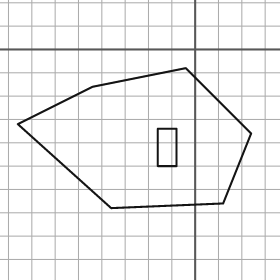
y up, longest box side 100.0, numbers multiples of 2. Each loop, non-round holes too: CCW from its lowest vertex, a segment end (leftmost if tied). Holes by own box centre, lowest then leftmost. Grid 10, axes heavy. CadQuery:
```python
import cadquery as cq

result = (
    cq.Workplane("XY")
    .moveTo(-36.0, -68.0)
    .lineTo(12.0, -66.0)
    .lineTo(24.0, -36.0)
    .lineTo(-4.0, -8.0)
    .lineTo(-44.0, -16.0)
    .lineTo(-76.0, -32.0)
    .close()
    .moveTo(-16.0, -50.0)
    .lineTo(-8.0, -50.0)
    .lineTo(-8.0, -34.0)
    .lineTo(-16.0, -34.0)
    .close()
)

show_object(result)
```